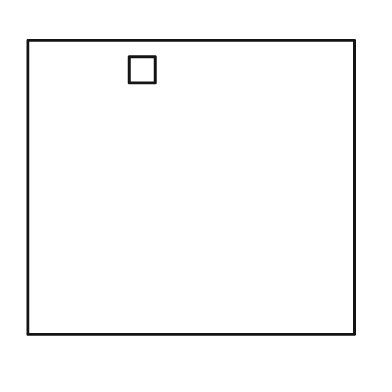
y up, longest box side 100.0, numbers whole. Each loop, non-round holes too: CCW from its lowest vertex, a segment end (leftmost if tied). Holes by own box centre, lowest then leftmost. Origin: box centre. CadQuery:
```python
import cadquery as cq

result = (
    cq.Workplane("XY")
    .moveTo(-50.0, -45.0)
    .lineTo(50.0, -45.0)
    .lineTo(50.0, 45.0)
    .lineTo(-50.0, 45.0)
    .close()
    .moveTo(-19.0, 32.0)
    .lineTo(-11.0, 32.0)
    .lineTo(-11.0, 40.0)
    .lineTo(-19.0, 40.0)
    .close()
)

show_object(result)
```